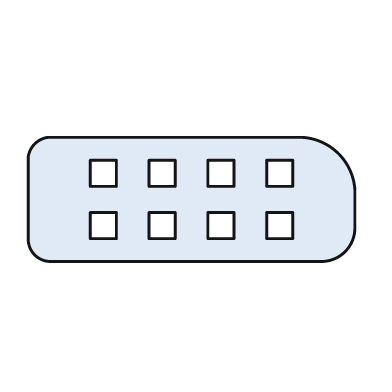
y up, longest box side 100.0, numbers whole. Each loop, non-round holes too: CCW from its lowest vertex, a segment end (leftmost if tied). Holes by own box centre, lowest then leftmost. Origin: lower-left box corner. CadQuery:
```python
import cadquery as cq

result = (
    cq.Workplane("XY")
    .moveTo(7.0, 0.0)
    .lineTo(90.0, 0.0)
    .threePointArc((97.0, 3.0), (100.0, 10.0))
    .lineTo(100.0, 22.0)
    .threePointArc((95.0, 33.0), (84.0, 38.0))
    .lineTo(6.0, 38.0)
    .threePointArc((2.0, 36.0), (0.0, 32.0))
    .lineTo(0.0, 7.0)
    .threePointArc((2.0, 2.0), (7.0, 0.0))
    .close()
    .moveTo(19.0, 7.0)
    .lineTo(27.0, 7.0)
    .lineTo(27.0, 15.0)
    .lineTo(19.0, 15.0)
    .close()
    .moveTo(37.0, 7.0)
    .lineTo(45.0, 7.0)
    .lineTo(45.0, 15.0)
    .lineTo(37.0, 15.0)
    .close()
    .moveTo(55.0, 7.0)
    .lineTo(63.0, 7.0)
    .lineTo(63.0, 15.0)
    .lineTo(55.0, 15.0)
    .close()
    .moveTo(73.0, 7.0)
    .lineTo(81.0, 7.0)
    .lineTo(81.0, 15.0)
    .lineTo(73.0, 15.0)
    .close()
    .moveTo(19.0, 23.0)
    .lineTo(27.0, 23.0)
    .lineTo(27.0, 31.0)
    .lineTo(19.0, 31.0)
    .close()
    .moveTo(37.0, 23.0)
    .lineTo(45.0, 23.0)
    .lineTo(45.0, 31.0)
    .lineTo(37.0, 31.0)
    .close()
    .moveTo(55.0, 23.0)
    .lineTo(63.0, 23.0)
    .lineTo(63.0, 31.0)
    .lineTo(55.0, 31.0)
    .close()
    .moveTo(73.0, 23.0)
    .lineTo(81.0, 23.0)
    .lineTo(81.0, 31.0)
    .lineTo(73.0, 31.0)
    .close()
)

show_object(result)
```